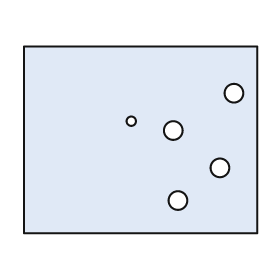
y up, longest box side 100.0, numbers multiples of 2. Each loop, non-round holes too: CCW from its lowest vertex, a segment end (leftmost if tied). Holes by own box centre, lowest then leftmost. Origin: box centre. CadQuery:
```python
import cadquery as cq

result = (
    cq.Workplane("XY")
    .moveTo(-50.0, -40.0)
    .lineTo(50.0, -40.0)
    .lineTo(50.0, 40.0)
    .lineTo(-50.0, 40.0)
    .close()
    .moveTo(16.0, -26.0)
    .circle(4.0)
    .moveTo(34.0, -12.0)
    .circle(4.0)
    .moveTo(14.0, 4.0)
    .circle(4.0)
    .moveTo(-4.0, 8.0)
    .circle(2.0)
    .moveTo(40.0, 20.0)
    .circle(4.0)
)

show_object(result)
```